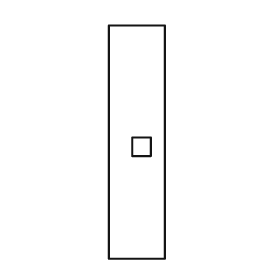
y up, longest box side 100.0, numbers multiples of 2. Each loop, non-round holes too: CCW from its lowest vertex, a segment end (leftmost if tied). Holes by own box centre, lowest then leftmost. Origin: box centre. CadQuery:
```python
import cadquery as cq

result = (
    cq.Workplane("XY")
    .moveTo(-12.0, -50.0)
    .lineTo(12.0, -50.0)
    .lineTo(12.0, 50.0)
    .lineTo(-12.0, 50.0)
    .close()
    .moveTo(-2.0, -6.0)
    .lineTo(6.0, -6.0)
    .lineTo(6.0, 2.0)
    .lineTo(-2.0, 2.0)
    .close()
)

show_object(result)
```